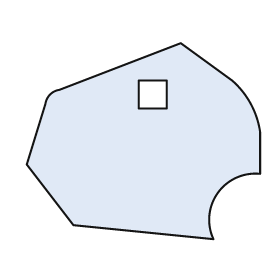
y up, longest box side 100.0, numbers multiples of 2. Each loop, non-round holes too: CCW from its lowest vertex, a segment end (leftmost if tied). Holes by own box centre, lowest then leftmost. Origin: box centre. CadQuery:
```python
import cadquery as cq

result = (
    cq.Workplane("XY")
    .moveTo(30.0, -42.0)
    .threePointArc((32.0, -22.0), (50.0, -14.0))
    .lineTo(50.0, 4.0)
    .threePointArc((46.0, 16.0), (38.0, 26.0))
    .lineTo(16.0, 42.0)
    .lineTo(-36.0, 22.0)
    .threePointArc((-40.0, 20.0), (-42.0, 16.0))
    .lineTo(-50.0, -10.0)
    .lineTo(-30.0, -36.0)
    .close()
    .moveTo(-2.0, 14.0)
    .lineTo(10.0, 14.0)
    .lineTo(10.0, 26.0)
    .lineTo(-2.0, 26.0)
    .close()
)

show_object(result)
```